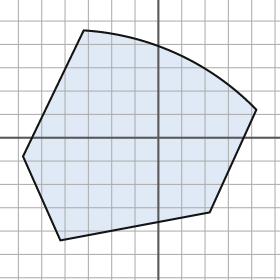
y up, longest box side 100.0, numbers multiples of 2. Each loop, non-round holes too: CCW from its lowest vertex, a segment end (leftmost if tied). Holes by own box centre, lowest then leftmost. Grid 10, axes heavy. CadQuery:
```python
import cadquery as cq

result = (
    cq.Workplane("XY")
    .moveTo(-42.0, -44.0)
    .lineTo(22.0, -32.0)
    .lineTo(42.0, 12.0)
    .threePointArc((8.0, 36.0), (-32.0, 46.0))
    .lineTo(-58.0, -8.0)
    .close()
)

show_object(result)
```